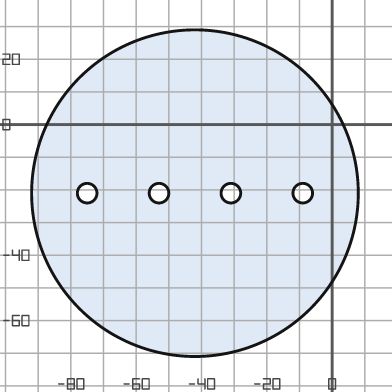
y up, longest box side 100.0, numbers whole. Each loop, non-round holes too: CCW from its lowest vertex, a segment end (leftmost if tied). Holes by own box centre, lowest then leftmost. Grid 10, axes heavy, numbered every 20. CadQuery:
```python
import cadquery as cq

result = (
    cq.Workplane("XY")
    .moveTo(-42.0, -21.0)
    .circle(50.0)
    .moveTo(-75.0, -21.0)
    .circle(3.0)
    .moveTo(-53.0, -21.0)
    .circle(3.0)
    .moveTo(-31.0, -21.0)
    .circle(3.0)
    .moveTo(-9.0, -21.0)
    .circle(3.0)
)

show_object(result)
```